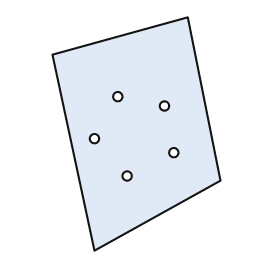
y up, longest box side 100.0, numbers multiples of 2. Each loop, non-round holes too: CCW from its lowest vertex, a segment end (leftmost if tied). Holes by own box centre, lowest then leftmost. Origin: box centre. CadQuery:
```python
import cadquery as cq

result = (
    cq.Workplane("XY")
    .moveTo(-18.0, -50.0)
    .lineTo(36.0, -20.0)
    .lineTo(22.0, 50.0)
    .lineTo(-36.0, 34.0)
    .close()
    .moveTo(-4.0, -18.0)
    .circle(2.0)
    .moveTo(16.0, -8.0)
    .circle(2.0)
    .moveTo(-18.0, -2.0)
    .circle(2.0)
    .moveTo(12.0, 12.0)
    .circle(2.0)
    .moveTo(-8.0, 16.0)
    .circle(2.0)
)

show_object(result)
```